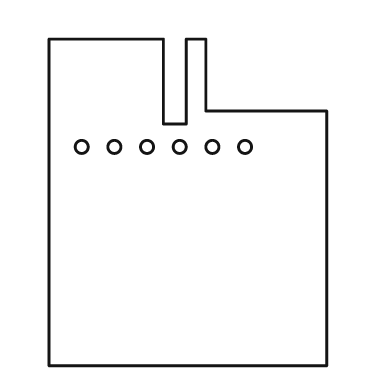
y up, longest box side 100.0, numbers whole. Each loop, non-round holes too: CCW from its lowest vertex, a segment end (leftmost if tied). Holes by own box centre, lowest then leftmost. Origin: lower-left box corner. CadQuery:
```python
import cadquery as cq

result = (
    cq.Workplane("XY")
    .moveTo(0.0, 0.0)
    .lineTo(85.0, 0.0)
    .lineTo(85.0, 78.0)
    .lineTo(48.0, 78.0)
    .lineTo(48.0, 100.0)
    .lineTo(42.0, 100.0)
    .lineTo(42.0, 74.0)
    .lineTo(35.0, 74.0)
    .lineTo(35.0, 100.0)
    .lineTo(0.0, 100.0)
    .close()
    .moveTo(10.0, 67.0)
    .circle(2.0)
    .moveTo(20.0, 67.0)
    .circle(2.0)
    .moveTo(30.0, 67.0)
    .circle(2.0)
    .moveTo(40.0, 67.0)
    .circle(2.0)
    .moveTo(50.0, 67.0)
    .circle(2.0)
    .moveTo(60.0, 67.0)
    .circle(2.0)
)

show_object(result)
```